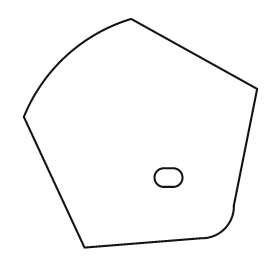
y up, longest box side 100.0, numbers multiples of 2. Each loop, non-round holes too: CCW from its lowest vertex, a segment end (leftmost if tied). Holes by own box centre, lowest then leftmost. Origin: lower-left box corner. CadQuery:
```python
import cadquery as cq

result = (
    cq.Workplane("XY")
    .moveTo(26.0, 0.0)
    .lineTo(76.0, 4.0)
    .threePointArc((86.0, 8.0), (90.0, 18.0))
    .lineTo(100.0, 68.0)
    .lineTo(46.0, 98.0)
    .threePointArc((18.0, 82.0), (0.0, 56.0))
    .close()
    .moveTo(60.0, 26.0)
    .lineTo(64.0, 26.0)
    .threePointArc((68.0, 30.0), (64.0, 34.0))
    .lineTo(60.0, 34.0)
    .threePointArc((56.0, 30.0), (60.0, 26.0))
    .close()
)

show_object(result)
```